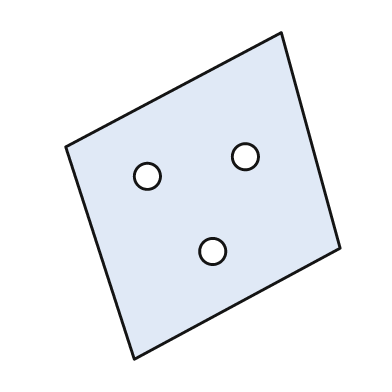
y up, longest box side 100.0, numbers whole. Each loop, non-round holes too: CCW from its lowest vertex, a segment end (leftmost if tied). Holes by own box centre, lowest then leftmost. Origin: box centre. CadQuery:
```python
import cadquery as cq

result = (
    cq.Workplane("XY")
    .moveTo(-21.0, -50.0)
    .lineTo(42.0, -16.0)
    .lineTo(24.0, 50.0)
    .lineTo(-42.0, 15.0)
    .close()
    .moveTo(3.0, -17.0)
    .circle(4.0)
    .moveTo(-17.0, 6.0)
    .circle(4.0)
    .moveTo(13.0, 12.0)
    .circle(4.0)
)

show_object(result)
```